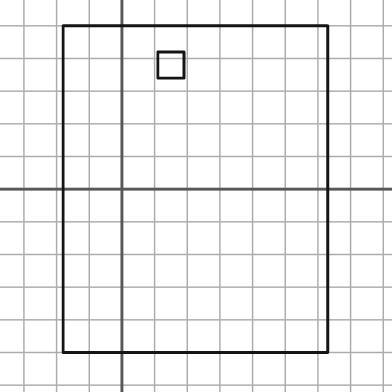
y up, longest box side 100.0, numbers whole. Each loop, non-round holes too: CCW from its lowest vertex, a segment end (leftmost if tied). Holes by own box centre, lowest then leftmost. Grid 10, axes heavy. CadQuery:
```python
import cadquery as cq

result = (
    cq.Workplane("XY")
    .moveTo(-18.0, -50.0)
    .lineTo(63.0, -50.0)
    .lineTo(63.0, 50.0)
    .lineTo(-18.0, 50.0)
    .close()
    .moveTo(11.0, 34.0)
    .lineTo(19.0, 34.0)
    .lineTo(19.0, 42.0)
    .lineTo(11.0, 42.0)
    .close()
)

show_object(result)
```